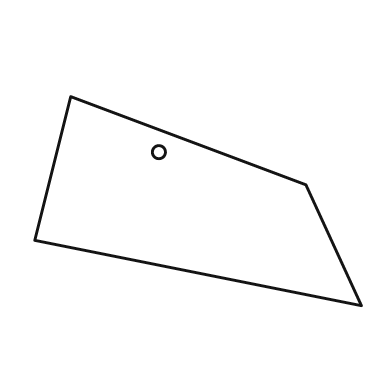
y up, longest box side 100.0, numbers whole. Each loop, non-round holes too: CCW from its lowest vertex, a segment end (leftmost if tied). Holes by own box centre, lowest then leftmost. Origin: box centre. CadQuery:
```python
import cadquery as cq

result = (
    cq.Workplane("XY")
    .moveTo(50.0, -32.0)
    .lineTo(33.0, 5.0)
    .lineTo(-39.0, 32.0)
    .lineTo(-50.0, -12.0)
    .close()
    .moveTo(-12.0, 15.0)
    .circle(2.0)
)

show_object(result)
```